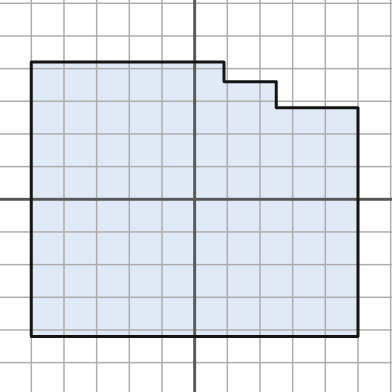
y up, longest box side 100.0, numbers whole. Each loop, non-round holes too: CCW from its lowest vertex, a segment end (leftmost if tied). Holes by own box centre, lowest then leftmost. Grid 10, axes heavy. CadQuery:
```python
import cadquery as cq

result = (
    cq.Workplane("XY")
    .moveTo(-50.0, -42.0)
    .lineTo(50.0, -42.0)
    .lineTo(50.0, 28.0)
    .lineTo(25.0, 28.0)
    .lineTo(25.0, 36.0)
    .lineTo(9.0, 36.0)
    .lineTo(9.0, 42.0)
    .lineTo(-50.0, 42.0)
    .close()
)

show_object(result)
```